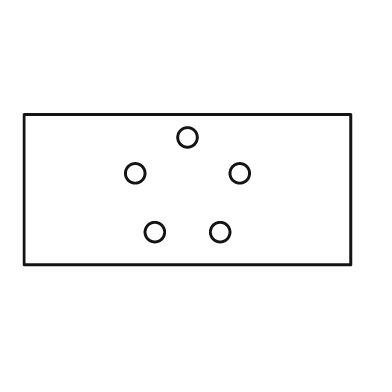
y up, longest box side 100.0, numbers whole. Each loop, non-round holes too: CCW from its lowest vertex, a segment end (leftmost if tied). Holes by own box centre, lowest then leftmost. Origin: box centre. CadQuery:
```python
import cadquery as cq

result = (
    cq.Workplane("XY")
    .moveTo(-50.0, -23.0)
    .lineTo(50.0, -23.0)
    .lineTo(50.0, 23.0)
    .lineTo(-50.0, 23.0)
    .close()
    .moveTo(-10.0, -13.0)
    .circle(3.0)
    .moveTo(10.0, -13.0)
    .circle(3.0)
    .moveTo(-16.0, 5.0)
    .circle(3.0)
    .moveTo(16.0, 5.0)
    .circle(3.0)
    .moveTo(0.0, 16.0)
    .circle(3.0)
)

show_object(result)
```